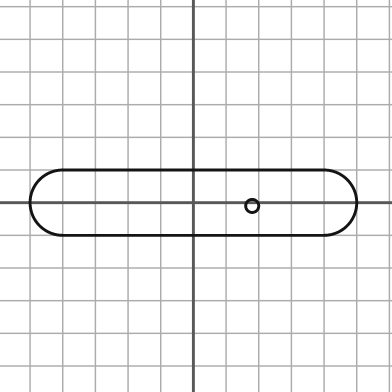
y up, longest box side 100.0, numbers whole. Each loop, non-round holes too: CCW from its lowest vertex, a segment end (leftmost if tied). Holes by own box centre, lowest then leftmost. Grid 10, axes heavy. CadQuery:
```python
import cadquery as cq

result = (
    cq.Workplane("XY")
    .moveTo(-40.0, -10.0)
    .lineTo(40.0, -10.0)
    .threePointArc((50.0, 0.0), (40.0, 10.0))
    .lineTo(-40.0, 10.0)
    .threePointArc((-50.0, 0.0), (-40.0, -10.0))
    .close()
    .moveTo(18.0, -1.0)
    .circle(2.0)
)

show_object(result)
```